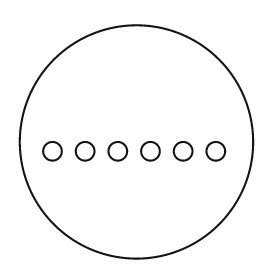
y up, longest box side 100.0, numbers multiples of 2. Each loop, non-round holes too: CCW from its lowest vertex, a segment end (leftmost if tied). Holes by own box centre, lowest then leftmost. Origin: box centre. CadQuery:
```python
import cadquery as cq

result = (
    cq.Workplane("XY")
    .moveTo(0.0, 0.0)
    .circle(50.0)
    .moveTo(-36.0, -4.0)
    .circle(4.0)
    .moveTo(-22.0, -4.0)
    .circle(4.0)
    .moveTo(-8.0, -4.0)
    .circle(4.0)
    .moveTo(6.0, -4.0)
    .circle(4.0)
    .moveTo(20.0, -4.0)
    .circle(4.0)
    .moveTo(34.0, -4.0)
    .circle(4.0)
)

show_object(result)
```